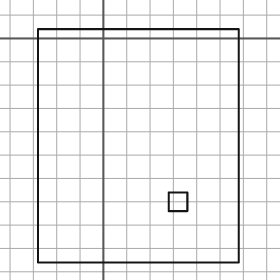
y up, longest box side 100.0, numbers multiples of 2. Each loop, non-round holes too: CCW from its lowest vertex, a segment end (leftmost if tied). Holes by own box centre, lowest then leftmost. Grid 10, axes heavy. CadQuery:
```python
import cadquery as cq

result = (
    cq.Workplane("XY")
    .moveTo(-28.0, -96.0)
    .lineTo(58.0, -96.0)
    .lineTo(58.0, 4.0)
    .lineTo(-28.0, 4.0)
    .close()
    .moveTo(28.0, -74.0)
    .lineTo(36.0, -74.0)
    .lineTo(36.0, -66.0)
    .lineTo(28.0, -66.0)
    .close()
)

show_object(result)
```